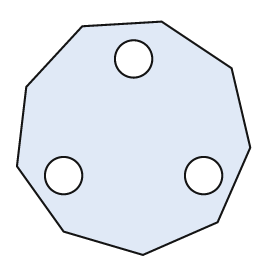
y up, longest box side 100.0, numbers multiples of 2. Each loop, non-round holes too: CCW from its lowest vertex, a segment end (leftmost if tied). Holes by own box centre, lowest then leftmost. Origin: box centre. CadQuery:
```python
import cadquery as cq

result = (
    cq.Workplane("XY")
    .moveTo(4.0, -50.0)
    .lineTo(36.0, -36.0)
    .lineTo(50.0, -4.0)
    .lineTo(42.0, 30.0)
    .lineTo(12.0, 50.0)
    .lineTo(-22.0, 48.0)
    .lineTo(-46.0, 22.0)
    .lineTo(-50.0, -12.0)
    .lineTo(-30.0, -40.0)
    .close()
    .moveTo(-30.0, -16.0)
    .circle(8.0)
    .moveTo(30.0, -16.0)
    .circle(8.0)
    .moveTo(0.0, 34.0)
    .circle(8.0)
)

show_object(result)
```